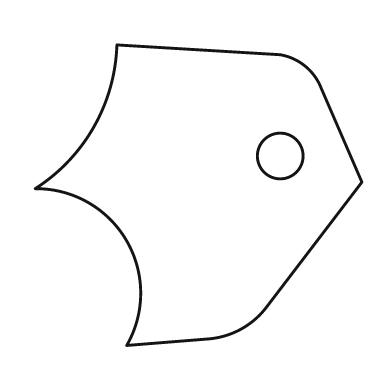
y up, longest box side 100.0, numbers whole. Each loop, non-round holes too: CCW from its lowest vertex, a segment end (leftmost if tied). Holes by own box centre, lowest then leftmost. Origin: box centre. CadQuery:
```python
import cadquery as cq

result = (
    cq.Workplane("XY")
    .moveTo(-22.0, -46.0)
    .lineTo(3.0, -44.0)
    .threePointArc((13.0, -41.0), (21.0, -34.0))
    .lineTo(50.0, 4.0)
    .lineTo(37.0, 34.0)
    .threePointArc((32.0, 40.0), (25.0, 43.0))
    .lineTo(-25.0, 46.0)
    .threePointArc((-32.0, 21.0), (-50.0, 2.0))
    .threePointArc((-22.0, -14.0), (-22.0, -46.0))
    .close()
    .moveTo(25.0, 12.0)
    .circle(7.0)
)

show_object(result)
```